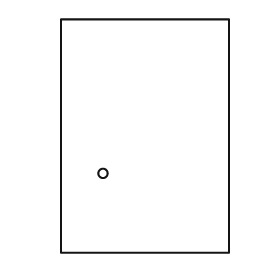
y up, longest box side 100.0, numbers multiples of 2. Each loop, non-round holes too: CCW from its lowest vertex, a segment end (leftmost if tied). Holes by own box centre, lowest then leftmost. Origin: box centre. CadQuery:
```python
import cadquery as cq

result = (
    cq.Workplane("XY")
    .moveTo(-36.0, -50.0)
    .lineTo(36.0, -50.0)
    .lineTo(36.0, 50.0)
    .lineTo(-36.0, 50.0)
    .close()
    .moveTo(-18.0, -16.0)
    .circle(2.0)
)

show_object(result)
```